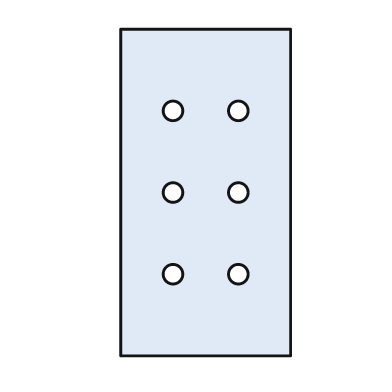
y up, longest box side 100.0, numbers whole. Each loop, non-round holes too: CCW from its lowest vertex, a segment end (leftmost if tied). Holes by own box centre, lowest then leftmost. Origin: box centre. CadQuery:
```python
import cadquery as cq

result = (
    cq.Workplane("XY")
    .moveTo(-26.0, -50.0)
    .lineTo(26.0, -50.0)
    .lineTo(26.0, 50.0)
    .lineTo(-26.0, 50.0)
    .close()
    .moveTo(-10.0, -25.0)
    .circle(3.0)
    .moveTo(10.0, -25.0)
    .circle(3.0)
    .moveTo(-10.0, 0.0)
    .circle(3.0)
    .moveTo(10.0, 0.0)
    .circle(3.0)
    .moveTo(-10.0, 25.0)
    .circle(3.0)
    .moveTo(10.0, 25.0)
    .circle(3.0)
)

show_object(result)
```